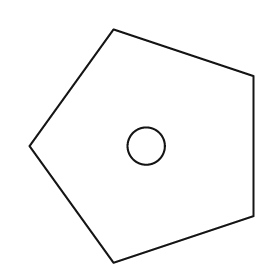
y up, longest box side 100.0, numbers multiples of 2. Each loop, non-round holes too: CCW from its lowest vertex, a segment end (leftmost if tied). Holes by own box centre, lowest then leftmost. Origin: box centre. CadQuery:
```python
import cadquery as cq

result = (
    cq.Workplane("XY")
    .moveTo(-12.0, -50.0)
    .lineTo(48.0, -30.0)
    .lineTo(48.0, 30.0)
    .lineTo(-12.0, 50.0)
    .lineTo(-48.0, 0.0)
    .close()
    .moveTo(2.0, 0.0)
    .circle(8.0)
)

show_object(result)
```